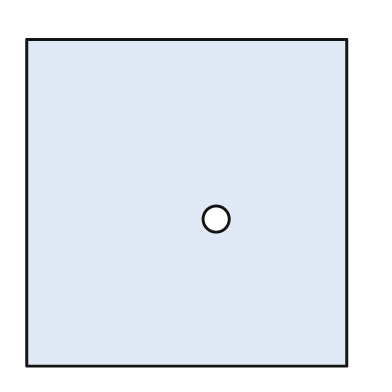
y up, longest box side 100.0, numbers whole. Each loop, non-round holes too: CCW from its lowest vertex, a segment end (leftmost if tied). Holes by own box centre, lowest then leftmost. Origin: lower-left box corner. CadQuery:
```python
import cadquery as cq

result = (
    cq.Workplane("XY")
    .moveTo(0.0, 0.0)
    .lineTo(98.0, 0.0)
    .lineTo(98.0, 100.0)
    .lineTo(0.0, 100.0)
    .close()
    .moveTo(58.0, 45.0)
    .circle(4.0)
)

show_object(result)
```